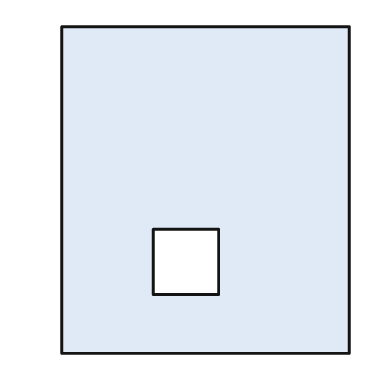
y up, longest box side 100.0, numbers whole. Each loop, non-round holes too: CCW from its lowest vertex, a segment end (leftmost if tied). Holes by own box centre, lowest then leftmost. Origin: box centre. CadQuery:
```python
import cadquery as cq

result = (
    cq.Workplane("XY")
    .moveTo(-44.0, -50.0)
    .lineTo(44.0, -50.0)
    .lineTo(44.0, 50.0)
    .lineTo(-44.0, 50.0)
    .close()
    .moveTo(-16.0, -32.0)
    .lineTo(4.0, -32.0)
    .lineTo(4.0, -12.0)
    .lineTo(-16.0, -12.0)
    .close()
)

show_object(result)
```